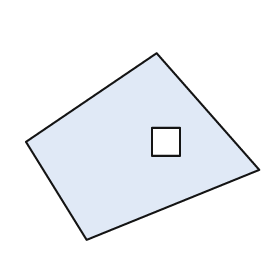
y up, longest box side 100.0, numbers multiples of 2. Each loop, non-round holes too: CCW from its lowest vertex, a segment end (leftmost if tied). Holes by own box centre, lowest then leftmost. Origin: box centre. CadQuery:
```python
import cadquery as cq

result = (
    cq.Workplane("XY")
    .moveTo(-24.0, -40.0)
    .lineTo(50.0, -10.0)
    .lineTo(6.0, 40.0)
    .lineTo(-50.0, 2.0)
    .close()
    .moveTo(4.0, -4.0)
    .lineTo(16.0, -4.0)
    .lineTo(16.0, 8.0)
    .lineTo(4.0, 8.0)
    .close()
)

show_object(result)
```